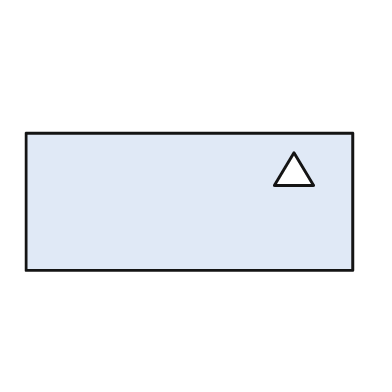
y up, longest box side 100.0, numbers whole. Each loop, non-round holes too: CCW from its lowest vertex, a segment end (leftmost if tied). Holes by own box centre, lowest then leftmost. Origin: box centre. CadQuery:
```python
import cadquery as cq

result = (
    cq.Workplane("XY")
    .moveTo(-50.0, -21.0)
    .lineTo(50.0, -21.0)
    .lineTo(50.0, 21.0)
    .lineTo(-50.0, 21.0)
    .close()
    .moveTo(26.0, 5.0)
    .lineTo(38.0, 5.0)
    .lineTo(32.0, 15.0)
    .close()
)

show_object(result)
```